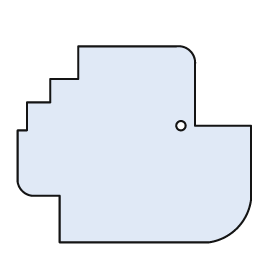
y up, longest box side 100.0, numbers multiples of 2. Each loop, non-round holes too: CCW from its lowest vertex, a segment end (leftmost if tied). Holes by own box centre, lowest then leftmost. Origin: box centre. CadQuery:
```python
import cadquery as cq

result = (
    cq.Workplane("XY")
    .moveTo(-32.0, -42.0)
    .lineTo(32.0, -42.0)
    .threePointArc((44.0, -36.0), (50.0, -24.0))
    .lineTo(50.0, 8.0)
    .lineTo(26.0, 8.0)
    .lineTo(26.0, 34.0)
    .threePointArc((24.0, 40.0), (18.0, 42.0))
    .lineTo(-24.0, 42.0)
    .lineTo(-24.0, 28.0)
    .lineTo(-36.0, 28.0)
    .lineTo(-36.0, 18.0)
    .lineTo(-46.0, 18.0)
    .lineTo(-46.0, 6.0)
    .lineTo(-50.0, 6.0)
    .lineTo(-50.0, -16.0)
    .threePointArc((-48.0, -20.0), (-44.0, -22.0))
    .lineTo(-32.0, -22.0)
    .close()
    .moveTo(20.0, 8.0)
    .circle(2.0)
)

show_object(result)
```